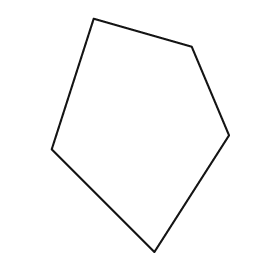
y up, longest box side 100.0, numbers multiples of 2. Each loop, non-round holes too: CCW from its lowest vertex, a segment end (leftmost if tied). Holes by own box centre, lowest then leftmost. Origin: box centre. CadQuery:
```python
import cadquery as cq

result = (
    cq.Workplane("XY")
    .moveTo(6.0, -50.0)
    .lineTo(38.0, 0.0)
    .lineTo(22.0, 38.0)
    .lineTo(-20.0, 50.0)
    .lineTo(-38.0, -6.0)
    .close()
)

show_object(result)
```